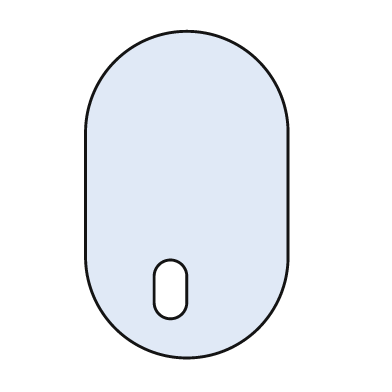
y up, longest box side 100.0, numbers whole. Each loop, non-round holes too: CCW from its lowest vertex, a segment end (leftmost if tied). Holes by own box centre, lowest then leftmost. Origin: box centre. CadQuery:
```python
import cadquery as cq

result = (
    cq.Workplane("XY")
    .moveTo(-31.0, -19.0)
    .threePointArc((0.0, -50.0), (31.0, -19.0))
    .lineTo(31.0, 19.0)
    .threePointArc((0.0, 50.0), (-31.0, 19.0))
    .close()
    .moveTo(-10.0, -33.0)
    .threePointArc((-5.0, -38.0), (0.0, -33.0))
    .lineTo(0.0, -25.0)
    .threePointArc((-5.0, -20.0), (-10.0, -25.0))
    .close()
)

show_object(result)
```